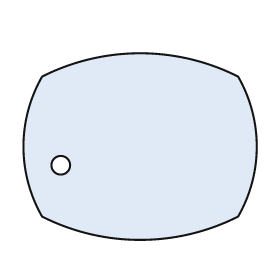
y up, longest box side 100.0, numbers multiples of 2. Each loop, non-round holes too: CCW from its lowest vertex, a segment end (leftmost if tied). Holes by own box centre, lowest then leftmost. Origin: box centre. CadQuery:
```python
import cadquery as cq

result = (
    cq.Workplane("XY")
    .moveTo(-42.0, -30.0)
    .threePointArc((0.0, -40.0), (42.0, -30.0))
    .threePointArc((50.0, 0.0), (42.0, 30.0))
    .threePointArc((0.0, 40.0), (-42.0, 30.0))
    .threePointArc((-50.0, 0.0), (-42.0, -30.0))
    .close()
    .moveTo(-34.0, -8.0)
    .circle(4.0)
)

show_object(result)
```